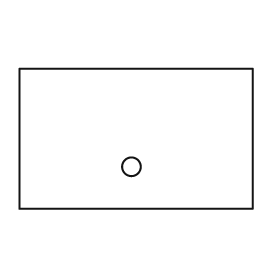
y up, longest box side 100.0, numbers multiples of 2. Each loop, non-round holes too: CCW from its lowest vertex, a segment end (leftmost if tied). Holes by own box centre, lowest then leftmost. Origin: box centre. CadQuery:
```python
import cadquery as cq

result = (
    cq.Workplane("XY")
    .moveTo(-50.0, -30.0)
    .lineTo(50.0, -30.0)
    .lineTo(50.0, 30.0)
    .lineTo(-50.0, 30.0)
    .close()
    .moveTo(-2.0, -12.0)
    .circle(4.0)
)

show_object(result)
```